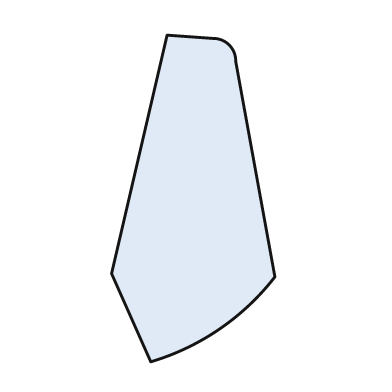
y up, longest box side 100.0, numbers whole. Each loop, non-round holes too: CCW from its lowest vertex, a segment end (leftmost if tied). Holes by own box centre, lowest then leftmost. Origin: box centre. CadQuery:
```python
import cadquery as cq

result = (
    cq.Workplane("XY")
    .moveTo(-13.0, -50.0)
    .threePointArc((8.0, -40.0), (25.0, -24.0))
    .lineTo(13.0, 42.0)
    .threePointArc((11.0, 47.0), (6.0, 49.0))
    .lineTo(-8.0, 50.0)
    .lineTo(-25.0, -23.0)
    .close()
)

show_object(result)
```